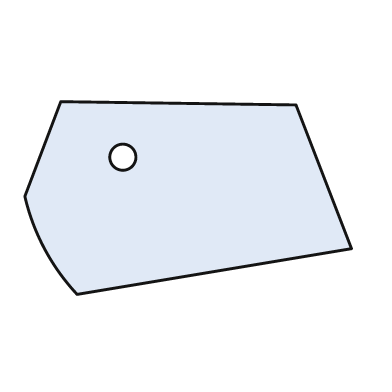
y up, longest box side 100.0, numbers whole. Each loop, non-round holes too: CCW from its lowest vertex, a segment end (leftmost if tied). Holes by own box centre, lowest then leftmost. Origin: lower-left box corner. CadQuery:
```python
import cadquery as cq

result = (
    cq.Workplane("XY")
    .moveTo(16.0, 0.0)
    .lineTo(100.0, 14.0)
    .lineTo(83.0, 58.0)
    .lineTo(11.0, 59.0)
    .lineTo(0.0, 30.0)
    .threePointArc((6.0, 14.0), (16.0, 0.0))
    .close()
    .moveTo(30.0, 42.0)
    .circle(4.0)
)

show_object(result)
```